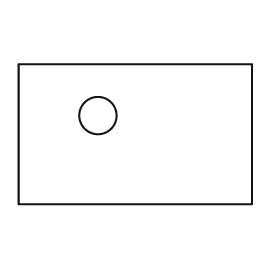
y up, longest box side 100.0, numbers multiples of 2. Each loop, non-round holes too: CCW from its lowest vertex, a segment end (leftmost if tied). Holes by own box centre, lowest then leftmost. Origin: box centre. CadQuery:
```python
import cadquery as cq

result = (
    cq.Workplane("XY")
    .moveTo(-50.0, -30.0)
    .lineTo(50.0, -30.0)
    .lineTo(50.0, 30.0)
    .lineTo(-50.0, 30.0)
    .close()
    .moveTo(-16.0, 8.0)
    .circle(8.0)
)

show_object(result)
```